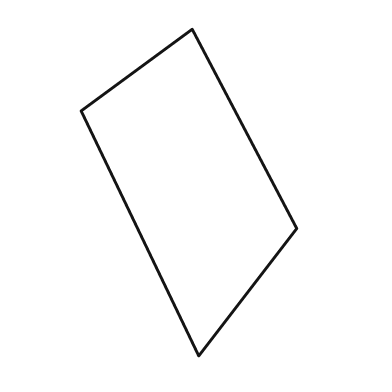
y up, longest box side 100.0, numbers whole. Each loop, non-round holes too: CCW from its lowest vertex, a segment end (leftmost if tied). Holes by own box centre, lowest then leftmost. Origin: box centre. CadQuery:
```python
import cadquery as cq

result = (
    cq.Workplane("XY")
    .moveTo(3.0, -50.0)
    .lineTo(33.0, -11.0)
    .lineTo(1.0, 50.0)
    .lineTo(-33.0, 25.0)
    .close()
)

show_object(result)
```